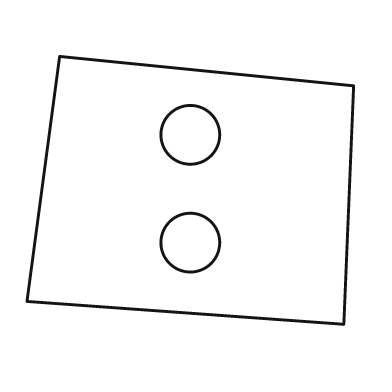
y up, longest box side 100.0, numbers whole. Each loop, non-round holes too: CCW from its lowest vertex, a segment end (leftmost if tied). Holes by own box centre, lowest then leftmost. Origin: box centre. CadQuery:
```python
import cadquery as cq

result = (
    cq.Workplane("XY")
    .moveTo(47.0, -41.0)
    .lineTo(50.0, 32.0)
    .lineTo(-40.0, 41.0)
    .lineTo(-50.0, -34.0)
    .close()
    .moveTo(0.0, -16.0)
    .circle(9.0)
    .moveTo(0.0, 17.0)
    .circle(9.0)
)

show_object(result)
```